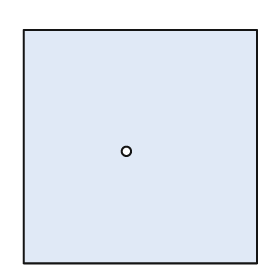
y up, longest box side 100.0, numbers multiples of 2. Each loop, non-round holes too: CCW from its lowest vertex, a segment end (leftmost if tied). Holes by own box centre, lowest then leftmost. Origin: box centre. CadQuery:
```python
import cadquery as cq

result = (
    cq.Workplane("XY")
    .moveTo(-50.0, -50.0)
    .lineTo(50.0, -50.0)
    .lineTo(50.0, 50.0)
    .lineTo(-50.0, 50.0)
    .close()
    .moveTo(-6.0, -2.0)
    .circle(2.0)
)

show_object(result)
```